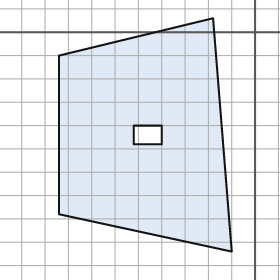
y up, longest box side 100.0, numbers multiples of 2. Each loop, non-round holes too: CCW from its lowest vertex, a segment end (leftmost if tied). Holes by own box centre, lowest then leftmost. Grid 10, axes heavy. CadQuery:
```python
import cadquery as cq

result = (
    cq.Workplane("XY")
    .moveTo(-10.0, -94.0)
    .lineTo(-18.0, 6.0)
    .lineTo(-84.0, -10.0)
    .lineTo(-84.0, -78.0)
    .close()
    .moveTo(-52.0, -48.0)
    .lineTo(-40.0, -48.0)
    .lineTo(-40.0, -40.0)
    .lineTo(-52.0, -40.0)
    .close()
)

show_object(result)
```